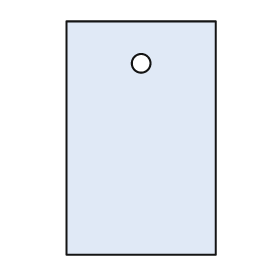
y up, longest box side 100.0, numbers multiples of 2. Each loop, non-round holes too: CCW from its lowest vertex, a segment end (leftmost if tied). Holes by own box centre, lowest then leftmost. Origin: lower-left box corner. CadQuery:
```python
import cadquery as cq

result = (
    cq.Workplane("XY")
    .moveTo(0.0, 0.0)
    .lineTo(64.0, 0.0)
    .lineTo(64.0, 100.0)
    .lineTo(0.0, 100.0)
    .close()
    .moveTo(32.0, 82.0)
    .circle(4.0)
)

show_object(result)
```